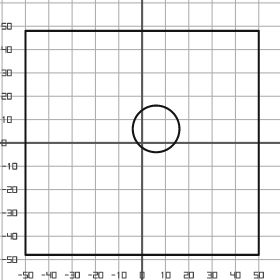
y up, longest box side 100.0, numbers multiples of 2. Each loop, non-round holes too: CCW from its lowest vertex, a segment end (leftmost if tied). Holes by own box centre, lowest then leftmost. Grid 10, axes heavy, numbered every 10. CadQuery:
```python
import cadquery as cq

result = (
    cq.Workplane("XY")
    .moveTo(-50.0, -48.0)
    .lineTo(50.0, -48.0)
    .lineTo(50.0, 48.0)
    .lineTo(-50.0, 48.0)
    .close()
    .moveTo(6.0, 6.0)
    .circle(10.0)
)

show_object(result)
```